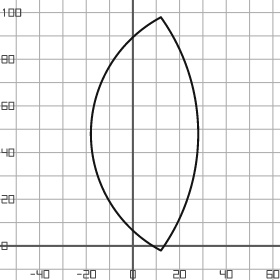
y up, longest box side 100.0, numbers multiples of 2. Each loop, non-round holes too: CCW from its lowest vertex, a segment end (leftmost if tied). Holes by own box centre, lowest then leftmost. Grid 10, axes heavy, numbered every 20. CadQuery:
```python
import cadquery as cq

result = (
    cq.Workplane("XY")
    .moveTo(12.0, -2.0)
    .threePointArc((28.0, 48.0), (12.0, 98.0))
    .threePointArc((-18.0, 48.0), (12.0, -2.0))
    .close()
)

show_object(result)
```